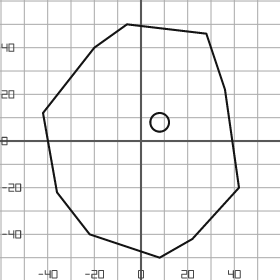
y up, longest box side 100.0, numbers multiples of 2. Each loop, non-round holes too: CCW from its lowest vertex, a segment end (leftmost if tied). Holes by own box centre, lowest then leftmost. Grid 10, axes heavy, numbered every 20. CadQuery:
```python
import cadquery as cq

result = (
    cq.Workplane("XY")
    .moveTo(8.0, -50.0)
    .lineTo(22.0, -42.0)
    .lineTo(42.0, -20.0)
    .lineTo(36.0, 22.0)
    .lineTo(28.0, 46.0)
    .lineTo(-6.0, 50.0)
    .lineTo(-20.0, 40.0)
    .lineTo(-42.0, 12.0)
    .lineTo(-36.0, -22.0)
    .lineTo(-22.0, -40.0)
    .close()
    .moveTo(8.0, 8.0)
    .circle(4.0)
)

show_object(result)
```